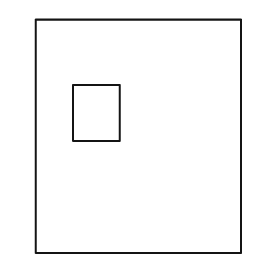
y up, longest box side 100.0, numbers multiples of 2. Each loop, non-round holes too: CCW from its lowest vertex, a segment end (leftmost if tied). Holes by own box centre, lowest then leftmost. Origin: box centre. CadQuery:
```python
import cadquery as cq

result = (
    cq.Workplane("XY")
    .moveTo(-44.0, -50.0)
    .lineTo(44.0, -50.0)
    .lineTo(44.0, 50.0)
    .lineTo(-44.0, 50.0)
    .close()
    .moveTo(-28.0, -2.0)
    .lineTo(-8.0, -2.0)
    .lineTo(-8.0, 22.0)
    .lineTo(-28.0, 22.0)
    .close()
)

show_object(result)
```